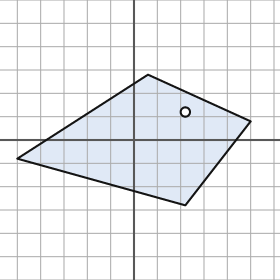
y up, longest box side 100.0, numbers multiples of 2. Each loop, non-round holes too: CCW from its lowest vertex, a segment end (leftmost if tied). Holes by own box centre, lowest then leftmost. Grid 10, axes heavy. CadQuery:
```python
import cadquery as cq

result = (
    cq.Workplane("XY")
    .moveTo(22.0, -28.0)
    .lineTo(50.0, 8.0)
    .lineTo(6.0, 28.0)
    .lineTo(-50.0, -8.0)
    .close()
    .moveTo(22.0, 12.0)
    .circle(2.0)
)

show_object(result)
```